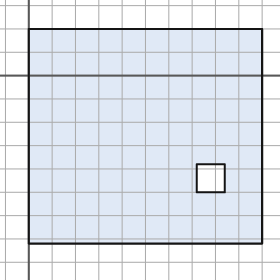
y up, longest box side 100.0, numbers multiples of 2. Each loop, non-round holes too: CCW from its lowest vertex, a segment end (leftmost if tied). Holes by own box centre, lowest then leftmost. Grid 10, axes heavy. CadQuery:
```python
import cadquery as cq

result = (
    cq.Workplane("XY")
    .moveTo(0.0, -72.0)
    .lineTo(100.0, -72.0)
    .lineTo(100.0, 20.0)
    .lineTo(0.0, 20.0)
    .close()
    .moveTo(72.0, -50.0)
    .lineTo(84.0, -50.0)
    .lineTo(84.0, -38.0)
    .lineTo(72.0, -38.0)
    .close()
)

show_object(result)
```